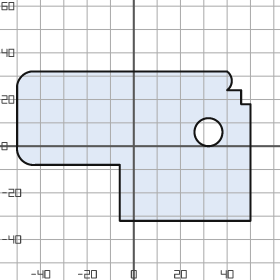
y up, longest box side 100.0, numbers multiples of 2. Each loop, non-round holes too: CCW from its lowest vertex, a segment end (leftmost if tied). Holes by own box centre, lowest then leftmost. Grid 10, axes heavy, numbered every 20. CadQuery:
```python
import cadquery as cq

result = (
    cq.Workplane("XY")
    .moveTo(-6.0, -32.0)
    .lineTo(50.0, -32.0)
    .lineTo(50.0, 18.0)
    .lineTo(46.0, 18.0)
    .lineTo(46.0, 24.0)
    .lineTo(40.0, 24.0)
    .threePointArc((42.0, 28.0), (40.0, 32.0))
    .lineTo(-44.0, 32.0)
    .threePointArc((-48.0, 30.0), (-50.0, 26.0))
    .lineTo(-50.0, 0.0)
    .threePointArc((-48.0, -6.0), (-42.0, -8.0))
    .lineTo(-6.0, -8.0)
    .close()
    .moveTo(32.0, 6.0)
    .circle(6.0)
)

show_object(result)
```